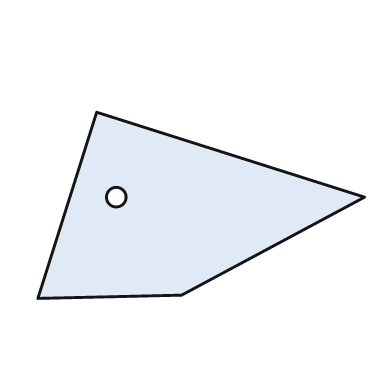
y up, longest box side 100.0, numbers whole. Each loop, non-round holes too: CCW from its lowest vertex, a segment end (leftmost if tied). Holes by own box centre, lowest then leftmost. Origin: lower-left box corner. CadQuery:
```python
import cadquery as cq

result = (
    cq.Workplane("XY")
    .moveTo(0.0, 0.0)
    .lineTo(44.0, 1.0)
    .lineTo(100.0, 31.0)
    .lineTo(18.0, 57.0)
    .close()
    .moveTo(24.0, 31.0)
    .circle(3.0)
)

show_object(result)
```